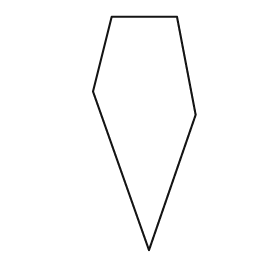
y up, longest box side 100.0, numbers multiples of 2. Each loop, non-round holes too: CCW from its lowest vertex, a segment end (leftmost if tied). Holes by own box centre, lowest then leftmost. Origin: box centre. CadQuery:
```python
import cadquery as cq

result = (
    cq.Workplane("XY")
    .moveTo(2.0, -50.0)
    .lineTo(22.0, 8.0)
    .lineTo(14.0, 50.0)
    .lineTo(-14.0, 50.0)
    .lineTo(-22.0, 18.0)
    .close()
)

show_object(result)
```